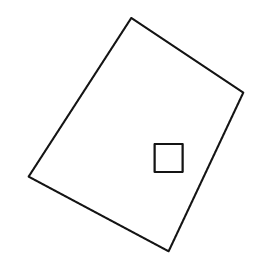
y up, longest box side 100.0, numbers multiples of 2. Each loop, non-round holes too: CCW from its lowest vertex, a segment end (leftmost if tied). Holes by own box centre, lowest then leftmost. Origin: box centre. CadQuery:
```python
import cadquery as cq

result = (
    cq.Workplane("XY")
    .moveTo(14.0, -50.0)
    .lineTo(46.0, 18.0)
    .lineTo(-2.0, 50.0)
    .lineTo(-46.0, -18.0)
    .close()
    .moveTo(8.0, -16.0)
    .lineTo(20.0, -16.0)
    .lineTo(20.0, -4.0)
    .lineTo(8.0, -4.0)
    .close()
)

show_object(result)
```